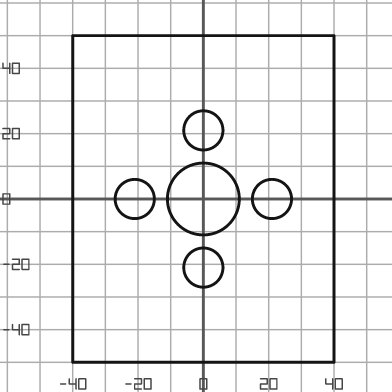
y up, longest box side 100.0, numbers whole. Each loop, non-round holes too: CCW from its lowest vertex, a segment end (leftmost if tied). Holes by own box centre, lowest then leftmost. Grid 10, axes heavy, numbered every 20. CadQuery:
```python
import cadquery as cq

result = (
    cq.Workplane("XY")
    .moveTo(-40.0, -50.0)
    .lineTo(40.0, -50.0)
    .lineTo(40.0, 50.0)
    .lineTo(-40.0, 50.0)
    .close()
    .moveTo(0.0, -21.0)
    .circle(6.0)
    .moveTo(-21.0, 0.0)
    .circle(6.0)
    .moveTo(0.0, 0.0)
    .circle(11.0)
    .moveTo(21.0, 0.0)
    .circle(6.0)
    .moveTo(0.0, 21.0)
    .circle(6.0)
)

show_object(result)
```